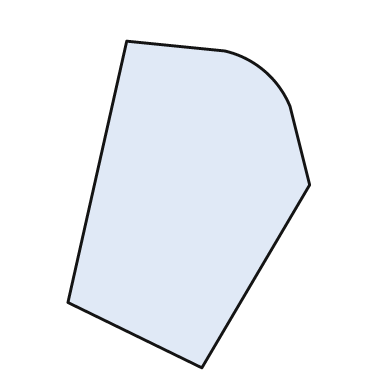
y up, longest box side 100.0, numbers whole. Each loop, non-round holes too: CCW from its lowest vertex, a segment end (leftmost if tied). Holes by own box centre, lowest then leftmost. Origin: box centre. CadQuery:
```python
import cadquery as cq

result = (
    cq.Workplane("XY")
    .moveTo(4.0, -50.0)
    .lineTo(37.0, 6.0)
    .lineTo(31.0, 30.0)
    .threePointArc((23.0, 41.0), (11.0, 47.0))
    .lineTo(-19.0, 50.0)
    .lineTo(-37.0, -30.0)
    .close()
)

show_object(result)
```